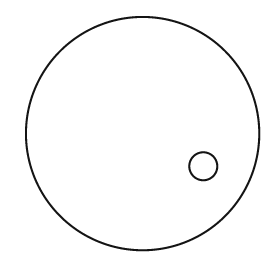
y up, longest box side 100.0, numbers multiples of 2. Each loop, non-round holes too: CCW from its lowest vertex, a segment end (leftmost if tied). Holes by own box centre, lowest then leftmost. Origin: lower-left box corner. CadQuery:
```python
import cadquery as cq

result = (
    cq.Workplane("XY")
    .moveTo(50.0, 50.0)
    .circle(50.0)
    .moveTo(76.0, 36.0)
    .circle(6.0)
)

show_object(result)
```